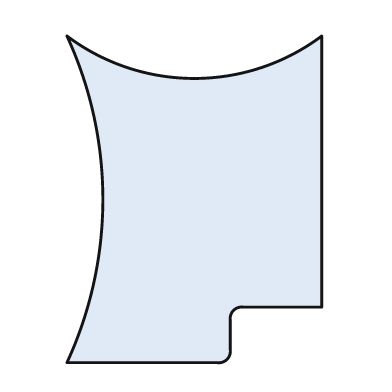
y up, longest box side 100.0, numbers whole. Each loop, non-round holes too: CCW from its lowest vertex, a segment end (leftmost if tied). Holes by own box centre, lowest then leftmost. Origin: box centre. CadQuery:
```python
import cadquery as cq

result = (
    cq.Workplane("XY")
    .moveTo(-39.0, -50.0)
    .lineTo(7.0, -50.0)
    .threePointArc((10.0, -49.0), (11.0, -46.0))
    .lineTo(11.0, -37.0)
    .threePointArc((12.0, -34.0), (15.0, -33.0))
    .lineTo(39.0, -33.0)
    .lineTo(39.0, 50.0)
    .threePointArc((0.0, 37.0), (-39.0, 50.0))
    .threePointArc((-28.0, 0.0), (-39.0, -50.0))
    .close()
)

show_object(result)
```